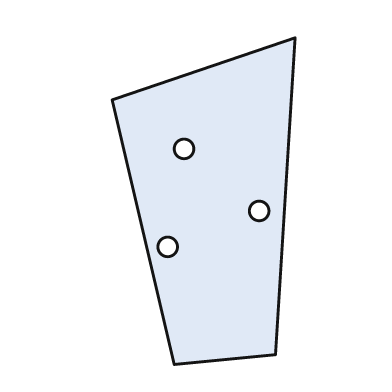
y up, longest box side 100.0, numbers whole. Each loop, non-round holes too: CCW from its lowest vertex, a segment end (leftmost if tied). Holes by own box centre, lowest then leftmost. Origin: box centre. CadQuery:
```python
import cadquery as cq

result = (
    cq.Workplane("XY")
    .moveTo(-9.0, -50.0)
    .lineTo(22.0, -47.0)
    .lineTo(28.0, 50.0)
    .lineTo(-28.0, 31.0)
    .close()
    .moveTo(-11.0, -14.0)
    .circle(3.0)
    .moveTo(17.0, -3.0)
    .circle(3.0)
    .moveTo(-6.0, 16.0)
    .circle(3.0)
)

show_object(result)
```